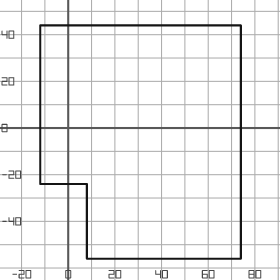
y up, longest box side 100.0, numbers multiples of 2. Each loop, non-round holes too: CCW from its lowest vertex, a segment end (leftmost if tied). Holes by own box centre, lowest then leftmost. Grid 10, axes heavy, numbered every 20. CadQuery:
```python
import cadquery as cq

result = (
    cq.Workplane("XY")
    .moveTo(8.0, -56.0)
    .lineTo(74.0, -56.0)
    .lineTo(74.0, 44.0)
    .lineTo(-12.0, 44.0)
    .lineTo(-12.0, -24.0)
    .lineTo(8.0, -24.0)
    .close()
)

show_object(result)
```